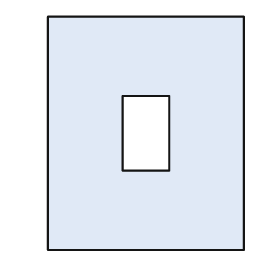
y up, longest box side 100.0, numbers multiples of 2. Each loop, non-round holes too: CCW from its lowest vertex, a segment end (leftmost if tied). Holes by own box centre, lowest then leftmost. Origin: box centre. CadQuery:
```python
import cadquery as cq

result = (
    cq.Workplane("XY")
    .moveTo(-42.0, -50.0)
    .lineTo(42.0, -50.0)
    .lineTo(42.0, 50.0)
    .lineTo(-42.0, 50.0)
    .close()
    .moveTo(-10.0, -16.0)
    .lineTo(10.0, -16.0)
    .lineTo(10.0, 16.0)
    .lineTo(-10.0, 16.0)
    .close()
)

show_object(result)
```